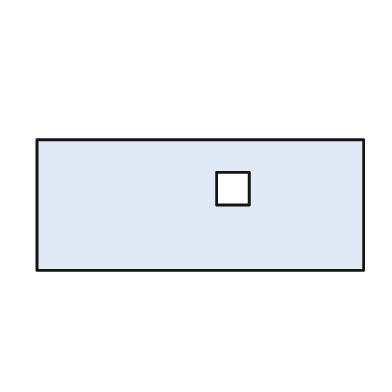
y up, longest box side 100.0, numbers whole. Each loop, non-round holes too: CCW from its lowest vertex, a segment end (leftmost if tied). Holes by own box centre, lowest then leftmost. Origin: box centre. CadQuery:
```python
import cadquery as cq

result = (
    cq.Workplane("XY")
    .moveTo(-50.0, -20.0)
    .lineTo(50.0, -20.0)
    .lineTo(50.0, 20.0)
    .lineTo(-50.0, 20.0)
    .close()
    .moveTo(5.0, 0.0)
    .lineTo(15.0, 0.0)
    .lineTo(15.0, 10.0)
    .lineTo(5.0, 10.0)
    .close()
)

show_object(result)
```